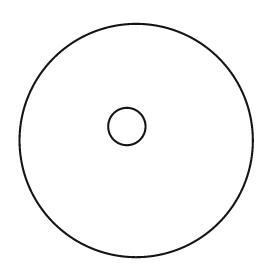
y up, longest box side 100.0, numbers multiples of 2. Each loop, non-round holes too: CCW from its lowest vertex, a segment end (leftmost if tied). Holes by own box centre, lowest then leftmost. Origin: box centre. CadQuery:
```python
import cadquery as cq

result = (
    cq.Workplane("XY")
    .moveTo(0.0, 0.0)
    .circle(50.0)
    .moveTo(-4.0, 6.0)
    .circle(8.0)
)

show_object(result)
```